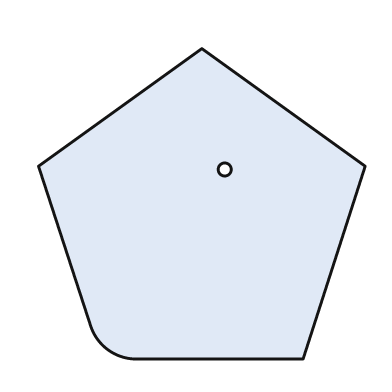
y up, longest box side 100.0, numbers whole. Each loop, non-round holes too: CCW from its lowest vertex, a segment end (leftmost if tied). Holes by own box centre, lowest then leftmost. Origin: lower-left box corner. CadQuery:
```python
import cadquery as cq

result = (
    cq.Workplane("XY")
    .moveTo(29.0, 0.0)
    .lineTo(81.0, 0.0)
    .lineTo(100.0, 59.0)
    .lineTo(50.0, 95.0)
    .lineTo(0.0, 59.0)
    .lineTo(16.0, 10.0)
    .threePointArc((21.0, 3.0), (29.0, 0.0))
    .close()
    .moveTo(57.0, 58.0)
    .circle(2.0)
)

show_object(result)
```